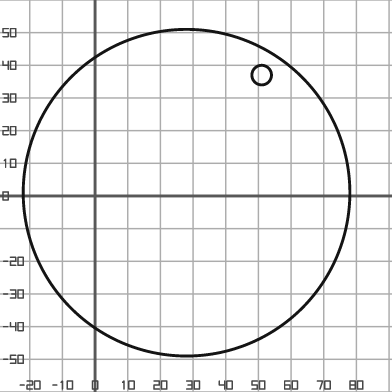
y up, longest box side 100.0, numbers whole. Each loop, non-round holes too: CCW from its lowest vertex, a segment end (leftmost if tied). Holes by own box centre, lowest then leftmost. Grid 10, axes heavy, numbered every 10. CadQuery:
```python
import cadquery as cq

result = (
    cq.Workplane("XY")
    .moveTo(28.0, 1.0)
    .circle(50.0)
    .moveTo(51.0, 37.0)
    .circle(3.0)
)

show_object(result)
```